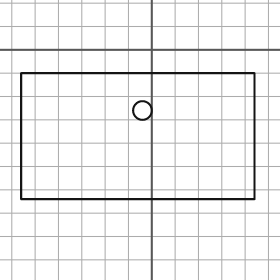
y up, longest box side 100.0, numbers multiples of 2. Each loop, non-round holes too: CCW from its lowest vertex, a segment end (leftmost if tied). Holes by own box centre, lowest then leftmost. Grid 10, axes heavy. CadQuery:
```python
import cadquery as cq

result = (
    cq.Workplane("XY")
    .moveTo(-56.0, -64.0)
    .lineTo(44.0, -64.0)
    .lineTo(44.0, -10.0)
    .lineTo(-56.0, -10.0)
    .close()
    .moveTo(-4.0, -26.0)
    .circle(4.0)
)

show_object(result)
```